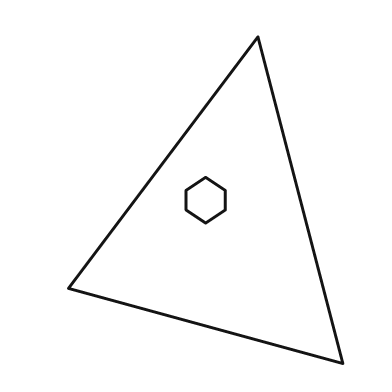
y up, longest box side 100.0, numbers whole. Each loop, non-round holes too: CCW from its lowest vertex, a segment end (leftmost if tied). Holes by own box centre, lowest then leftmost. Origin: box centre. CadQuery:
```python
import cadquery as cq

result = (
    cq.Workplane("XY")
    .moveTo(42.0, -50.0)
    .lineTo(16.0, 50.0)
    .lineTo(-42.0, -27.0)
    .close()
    .moveTo(0.0, -7.0)
    .lineTo(6.0, -3.0)
    .lineTo(6.0, 3.0)
    .lineTo(0.0, 7.0)
    .lineTo(-6.0, 3.0)
    .lineTo(-6.0, -3.0)
    .close()
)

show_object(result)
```